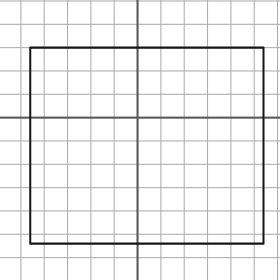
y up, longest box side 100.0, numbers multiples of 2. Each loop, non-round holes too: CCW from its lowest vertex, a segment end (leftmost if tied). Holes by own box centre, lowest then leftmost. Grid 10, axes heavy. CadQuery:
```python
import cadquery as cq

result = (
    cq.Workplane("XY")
    .moveTo(-46.0, -54.0)
    .lineTo(54.0, -54.0)
    .lineTo(54.0, 30.0)
    .lineTo(-46.0, 30.0)
    .close()
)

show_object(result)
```